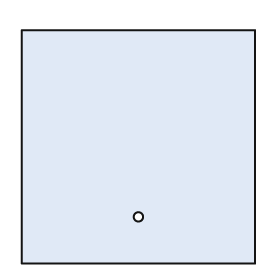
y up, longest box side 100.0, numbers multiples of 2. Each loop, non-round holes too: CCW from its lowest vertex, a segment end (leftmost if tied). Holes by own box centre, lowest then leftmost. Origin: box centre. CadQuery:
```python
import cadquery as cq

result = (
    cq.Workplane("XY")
    .moveTo(-50.0, -50.0)
    .lineTo(50.0, -50.0)
    .lineTo(50.0, 50.0)
    .lineTo(-50.0, 50.0)
    .close()
    .moveTo(0.0, -30.0)
    .circle(2.0)
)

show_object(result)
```